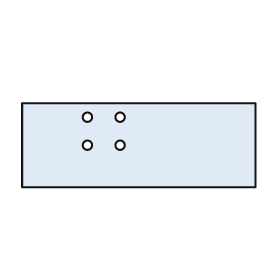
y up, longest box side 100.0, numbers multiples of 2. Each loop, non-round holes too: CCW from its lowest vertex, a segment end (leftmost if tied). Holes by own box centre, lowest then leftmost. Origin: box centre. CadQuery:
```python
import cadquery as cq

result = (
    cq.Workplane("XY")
    .moveTo(-50.0, -18.0)
    .lineTo(50.0, -18.0)
    .lineTo(50.0, 18.0)
    .lineTo(-50.0, 18.0)
    .close()
    .moveTo(-22.0, 0.0)
    .circle(2.0)
    .moveTo(-8.0, 0.0)
    .circle(2.0)
    .moveTo(-22.0, 12.0)
    .circle(2.0)
    .moveTo(-8.0, 12.0)
    .circle(2.0)
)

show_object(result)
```